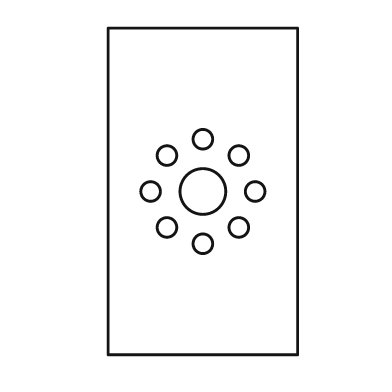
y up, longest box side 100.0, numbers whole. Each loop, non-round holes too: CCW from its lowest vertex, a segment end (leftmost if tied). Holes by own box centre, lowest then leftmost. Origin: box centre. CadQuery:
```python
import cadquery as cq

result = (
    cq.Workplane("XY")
    .moveTo(-29.0, -50.0)
    .lineTo(29.0, -50.0)
    .lineTo(29.0, 50.0)
    .lineTo(-29.0, 50.0)
    .close()
    .moveTo(0.0, -16.0)
    .circle(3.0)
    .moveTo(-11.0, -11.0)
    .circle(3.0)
    .moveTo(11.0, -11.0)
    .circle(3.0)
    .moveTo(-16.0, 0.0)
    .circle(3.0)
    .moveTo(0.0, 0.0)
    .circle(7.0)
    .moveTo(16.0, 0.0)
    .circle(3.0)
    .moveTo(-11.0, 11.0)
    .circle(3.0)
    .moveTo(11.0, 11.0)
    .circle(3.0)
    .moveTo(0.0, 16.0)
    .circle(3.0)
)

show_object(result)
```